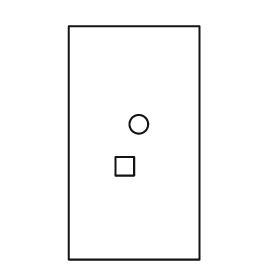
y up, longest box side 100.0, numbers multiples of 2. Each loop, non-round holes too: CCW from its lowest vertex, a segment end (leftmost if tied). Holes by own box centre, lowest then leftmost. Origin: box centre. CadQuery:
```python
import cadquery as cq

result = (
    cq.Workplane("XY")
    .moveTo(-28.0, -50.0)
    .lineTo(28.0, -50.0)
    .lineTo(28.0, 50.0)
    .lineTo(-28.0, 50.0)
    .close()
    .moveTo(-8.0, -14.0)
    .lineTo(0.0, -14.0)
    .lineTo(0.0, -6.0)
    .lineTo(-8.0, -6.0)
    .close()
    .moveTo(2.0, 8.0)
    .circle(4.0)
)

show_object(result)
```